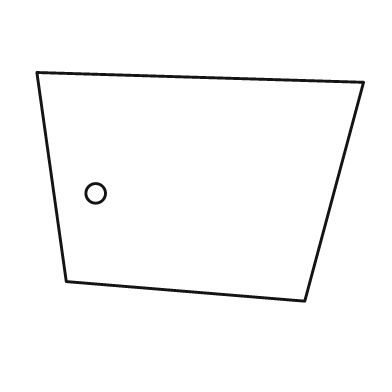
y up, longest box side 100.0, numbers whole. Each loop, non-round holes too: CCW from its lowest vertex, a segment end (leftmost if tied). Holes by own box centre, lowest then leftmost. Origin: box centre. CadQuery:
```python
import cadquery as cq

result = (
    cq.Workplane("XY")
    .moveTo(32.0, -35.0)
    .lineTo(50.0, 32.0)
    .lineTo(-50.0, 35.0)
    .lineTo(-41.0, -29.0)
    .close()
    .moveTo(-32.0, -2.0)
    .circle(3.0)
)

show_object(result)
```